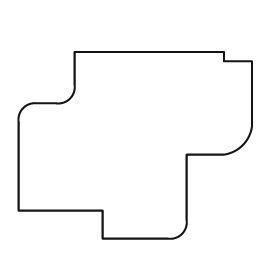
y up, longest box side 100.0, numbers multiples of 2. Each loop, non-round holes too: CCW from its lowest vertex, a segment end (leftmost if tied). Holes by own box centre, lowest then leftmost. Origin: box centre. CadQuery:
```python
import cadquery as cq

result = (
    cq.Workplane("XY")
    .moveTo(-14.0, -40.0)
    .lineTo(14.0, -40.0)
    .threePointArc((20.0, -38.0), (22.0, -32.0))
    .lineTo(22.0, -4.0)
    .lineTo(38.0, -4.0)
    .threePointArc((46.0, 0.0), (50.0, 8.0))
    .lineTo(50.0, 36.0)
    .lineTo(38.0, 36.0)
    .lineTo(38.0, 40.0)
    .lineTo(-26.0, 40.0)
    .lineTo(-26.0, 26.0)
    .threePointArc((-28.0, 20.0), (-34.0, 18.0))
    .lineTo(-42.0, 18.0)
    .threePointArc((-48.0, 16.0), (-50.0, 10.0))
    .lineTo(-50.0, -28.0)
    .lineTo(-14.0, -28.0)
    .close()
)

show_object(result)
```